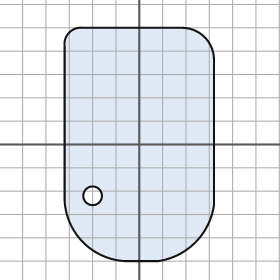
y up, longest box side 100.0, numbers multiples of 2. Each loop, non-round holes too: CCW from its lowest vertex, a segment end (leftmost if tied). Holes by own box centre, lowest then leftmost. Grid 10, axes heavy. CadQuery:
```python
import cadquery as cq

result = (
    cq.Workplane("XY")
    .moveTo(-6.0, -50.0)
    .lineTo(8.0, -50.0)
    .threePointArc((24.0, -42.0), (32.0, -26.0))
    .lineTo(32.0, 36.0)
    .threePointArc((28.0, 46.0), (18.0, 50.0))
    .lineTo(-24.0, 50.0)
    .threePointArc((-30.0, 48.0), (-32.0, 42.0))
    .lineTo(-32.0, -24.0)
    .threePointArc((-24.0, -42.0), (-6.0, -50.0))
    .close()
    .moveTo(-20.0, -22.0)
    .circle(4.0)
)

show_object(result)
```